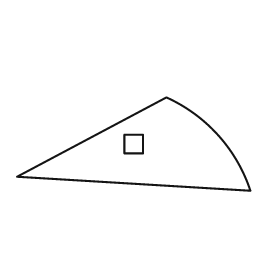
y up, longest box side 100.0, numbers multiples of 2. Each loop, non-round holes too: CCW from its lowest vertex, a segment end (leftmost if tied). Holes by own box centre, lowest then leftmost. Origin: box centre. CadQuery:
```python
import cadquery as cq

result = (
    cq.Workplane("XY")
    .moveTo(50.0, -20.0)
    .threePointArc((36.0, 4.0), (14.0, 20.0))
    .lineTo(-50.0, -14.0)
    .close()
    .moveTo(-4.0, -4.0)
    .lineTo(4.0, -4.0)
    .lineTo(4.0, 4.0)
    .lineTo(-4.0, 4.0)
    .close()
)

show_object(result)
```